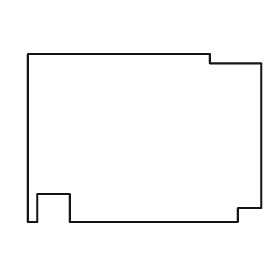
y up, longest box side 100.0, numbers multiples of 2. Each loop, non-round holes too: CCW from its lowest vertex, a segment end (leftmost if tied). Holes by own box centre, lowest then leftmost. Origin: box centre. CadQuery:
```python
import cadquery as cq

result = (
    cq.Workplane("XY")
    .moveTo(-50.0, -36.0)
    .lineTo(-46.0, -36.0)
    .lineTo(-46.0, -24.0)
    .lineTo(-32.0, -24.0)
    .lineTo(-32.0, -36.0)
    .lineTo(40.0, -36.0)
    .lineTo(40.0, -30.0)
    .lineTo(50.0, -30.0)
    .lineTo(50.0, 32.0)
    .lineTo(28.0, 32.0)
    .lineTo(28.0, 36.0)
    .lineTo(-50.0, 36.0)
    .close()
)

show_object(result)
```